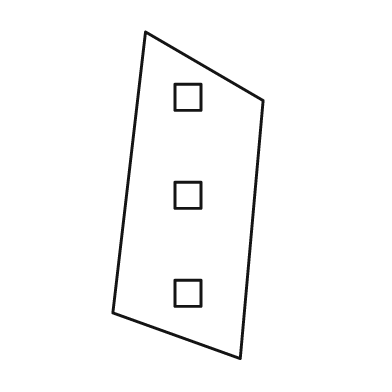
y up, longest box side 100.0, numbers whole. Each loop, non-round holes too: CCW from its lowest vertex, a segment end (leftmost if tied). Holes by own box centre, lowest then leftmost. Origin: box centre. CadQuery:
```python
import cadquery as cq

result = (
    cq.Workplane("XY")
    .moveTo(16.0, -50.0)
    .lineTo(23.0, 29.0)
    .lineTo(-13.0, 50.0)
    .lineTo(-23.0, -36.0)
    .close()
    .moveTo(-4.0, -34.0)
    .lineTo(4.0, -34.0)
    .lineTo(4.0, -26.0)
    .lineTo(-4.0, -26.0)
    .close()
    .moveTo(-4.0, -4.0)
    .lineTo(4.0, -4.0)
    .lineTo(4.0, 4.0)
    .lineTo(-4.0, 4.0)
    .close()
    .moveTo(-4.0, 26.0)
    .lineTo(4.0, 26.0)
    .lineTo(4.0, 34.0)
    .lineTo(-4.0, 34.0)
    .close()
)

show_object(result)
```